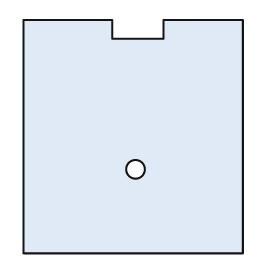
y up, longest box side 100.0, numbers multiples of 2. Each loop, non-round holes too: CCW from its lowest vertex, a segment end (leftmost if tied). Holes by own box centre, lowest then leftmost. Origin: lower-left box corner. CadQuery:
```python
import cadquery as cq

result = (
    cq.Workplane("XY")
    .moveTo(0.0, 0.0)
    .lineTo(94.0, 0.0)
    .lineTo(94.0, 100.0)
    .lineTo(60.0, 100.0)
    .lineTo(60.0, 92.0)
    .lineTo(38.0, 92.0)
    .lineTo(38.0, 100.0)
    .lineTo(0.0, 100.0)
    .close()
    .moveTo(48.0, 36.0)
    .circle(4.0)
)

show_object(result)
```